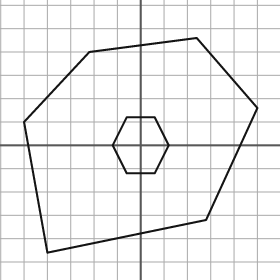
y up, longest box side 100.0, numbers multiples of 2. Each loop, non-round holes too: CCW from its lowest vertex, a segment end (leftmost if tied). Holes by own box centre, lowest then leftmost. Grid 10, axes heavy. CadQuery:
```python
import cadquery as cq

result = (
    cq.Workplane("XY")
    .moveTo(-40.0, -46.0)
    .lineTo(28.0, -32.0)
    .lineTo(50.0, 16.0)
    .lineTo(24.0, 46.0)
    .lineTo(-22.0, 40.0)
    .lineTo(-50.0, 10.0)
    .close()
    .moveTo(-6.0, -12.0)
    .lineTo(6.0, -12.0)
    .lineTo(12.0, 0.0)
    .lineTo(6.0, 12.0)
    .lineTo(-6.0, 12.0)
    .lineTo(-12.0, 0.0)
    .close()
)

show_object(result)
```